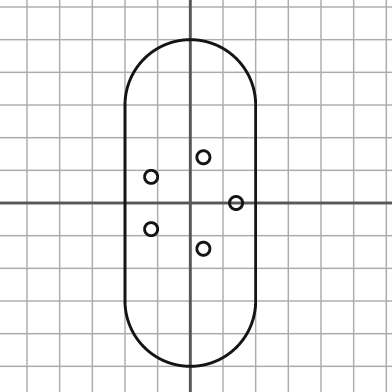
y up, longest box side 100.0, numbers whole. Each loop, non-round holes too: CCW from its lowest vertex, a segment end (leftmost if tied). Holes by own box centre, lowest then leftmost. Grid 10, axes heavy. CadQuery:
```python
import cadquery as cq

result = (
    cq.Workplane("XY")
    .moveTo(-20.0, -30.0)
    .threePointArc((0.0, -50.0), (20.0, -30.0))
    .lineTo(20.0, 30.0)
    .threePointArc((0.0, 50.0), (-20.0, 30.0))
    .close()
    .moveTo(4.0, -14.0)
    .circle(2.0)
    .moveTo(-12.0, -8.0)
    .circle(2.0)
    .moveTo(14.0, 0.0)
    .circle(2.0)
    .moveTo(-12.0, 8.0)
    .circle(2.0)
    .moveTo(4.0, 14.0)
    .circle(2.0)
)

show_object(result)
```